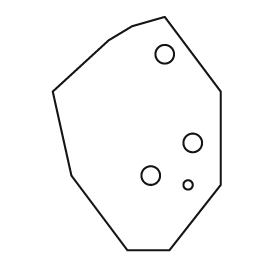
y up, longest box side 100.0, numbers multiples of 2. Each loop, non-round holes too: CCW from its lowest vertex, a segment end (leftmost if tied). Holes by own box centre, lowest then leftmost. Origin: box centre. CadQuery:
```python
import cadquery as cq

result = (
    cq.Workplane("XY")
    .moveTo(-4.0, -50.0)
    .lineTo(14.0, -50.0)
    .lineTo(36.0, -22.0)
    .lineTo(36.0, 18.0)
    .lineTo(12.0, 50.0)
    .lineTo(-2.0, 46.0)
    .lineTo(-12.0, 40.0)
    .lineTo(-36.0, 18.0)
    .lineTo(-28.0, -18.0)
    .close()
    .moveTo(22.0, -22.0)
    .circle(2.0)
    .moveTo(6.0, -18.0)
    .circle(4.0)
    .moveTo(24.0, -4.0)
    .circle(4.0)
    .moveTo(12.0, 34.0)
    .circle(4.0)
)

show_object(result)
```